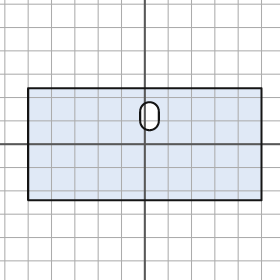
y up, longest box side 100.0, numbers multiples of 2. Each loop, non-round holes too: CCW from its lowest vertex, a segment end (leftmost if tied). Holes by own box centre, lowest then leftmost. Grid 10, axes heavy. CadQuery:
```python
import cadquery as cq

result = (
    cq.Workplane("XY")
    .moveTo(-50.0, -24.0)
    .lineTo(50.0, -24.0)
    .lineTo(50.0, 24.0)
    .lineTo(-50.0, 24.0)
    .close()
    .moveTo(-2.0, 10.0)
    .threePointArc((2.0, 6.0), (6.0, 10.0))
    .lineTo(6.0, 14.0)
    .threePointArc((2.0, 18.0), (-2.0, 14.0))
    .close()
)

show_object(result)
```